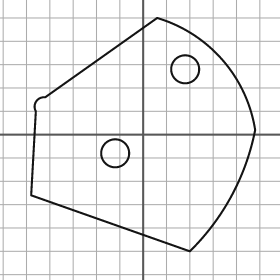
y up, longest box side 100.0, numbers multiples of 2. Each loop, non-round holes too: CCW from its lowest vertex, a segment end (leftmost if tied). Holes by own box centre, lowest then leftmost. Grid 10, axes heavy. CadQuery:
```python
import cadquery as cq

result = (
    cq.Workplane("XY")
    .moveTo(20.0, -50.0)
    .threePointArc((38.0, -26.0), (48.0, 2.0))
    .threePointArc((34.0, 32.0), (6.0, 50.0))
    .lineTo(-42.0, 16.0)
    .threePointArc((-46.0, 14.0), (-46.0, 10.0))
    .lineTo(-48.0, -26.0)
    .close()
    .moveTo(-12.0, -8.0)
    .circle(6.0)
    .moveTo(18.0, 28.0)
    .circle(6.0)
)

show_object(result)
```